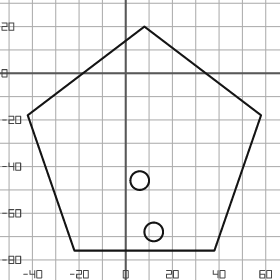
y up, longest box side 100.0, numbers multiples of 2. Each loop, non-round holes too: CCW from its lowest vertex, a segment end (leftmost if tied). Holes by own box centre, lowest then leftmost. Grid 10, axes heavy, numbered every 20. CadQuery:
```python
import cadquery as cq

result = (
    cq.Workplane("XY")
    .moveTo(-22.0, -76.0)
    .lineTo(38.0, -76.0)
    .lineTo(58.0, -18.0)
    .lineTo(8.0, 20.0)
    .lineTo(-42.0, -18.0)
    .close()
    .moveTo(12.0, -68.0)
    .circle(4.0)
    .moveTo(6.0, -46.0)
    .circle(4.0)
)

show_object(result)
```